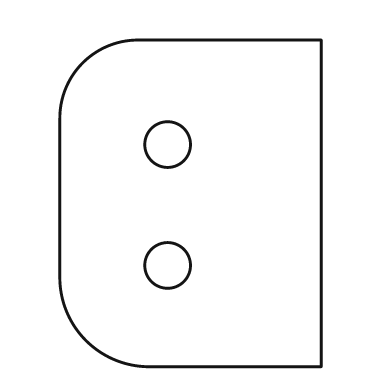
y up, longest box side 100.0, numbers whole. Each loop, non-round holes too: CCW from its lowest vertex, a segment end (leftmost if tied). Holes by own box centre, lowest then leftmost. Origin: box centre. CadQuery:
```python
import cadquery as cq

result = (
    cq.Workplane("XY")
    .moveTo(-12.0, -50.0)
    .lineTo(40.0, -50.0)
    .lineTo(40.0, 50.0)
    .lineTo(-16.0, 50.0)
    .threePointArc((-33.0, 43.0), (-40.0, 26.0))
    .lineTo(-40.0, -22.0)
    .threePointArc((-32.0, -42.0), (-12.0, -50.0))
    .close()
    .moveTo(-7.0, -19.0)
    .circle(7.0)
    .moveTo(-7.0, 18.0)
    .circle(7.0)
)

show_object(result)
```